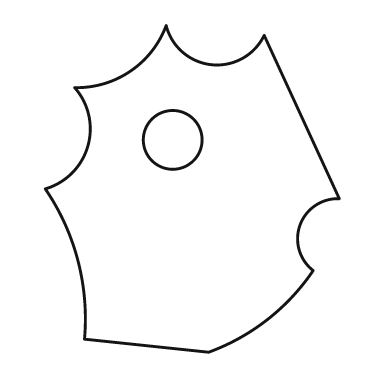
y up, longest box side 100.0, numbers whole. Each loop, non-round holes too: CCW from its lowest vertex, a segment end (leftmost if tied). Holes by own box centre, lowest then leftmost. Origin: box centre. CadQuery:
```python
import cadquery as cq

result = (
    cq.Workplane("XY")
    .moveTo(5.0, -50.0)
    .threePointArc((23.0, -40.0), (37.0, -25.0))
    .threePointArc((33.0, -11.0), (45.0, -3.0))
    .lineTo(22.0, 47.0)
    .threePointArc((6.0, 38.0), (-8.0, 50.0))
    .threePointArc((-19.0, 36.0), (-36.0, 31.0))
    .threePointArc((-32.0, 13.0), (-45.0, 0.0))
    .threePointArc((-35.0, -22.0), (-33.0, -46.0))
    .close()
    .moveTo(-6.0, 15.0)
    .circle(9.0)
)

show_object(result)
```